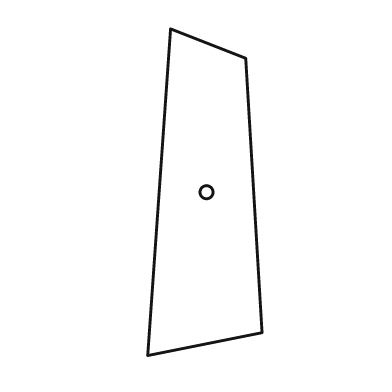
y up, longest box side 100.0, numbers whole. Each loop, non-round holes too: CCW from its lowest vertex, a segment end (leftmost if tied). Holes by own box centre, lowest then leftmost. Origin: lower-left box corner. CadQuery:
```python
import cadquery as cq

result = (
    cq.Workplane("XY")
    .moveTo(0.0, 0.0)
    .lineTo(35.0, 7.0)
    .lineTo(30.0, 91.0)
    .lineTo(7.0, 100.0)
    .close()
    .moveTo(18.0, 50.0)
    .circle(2.0)
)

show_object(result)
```